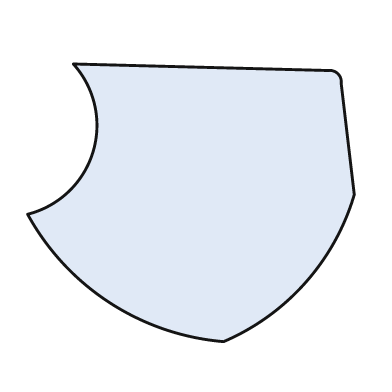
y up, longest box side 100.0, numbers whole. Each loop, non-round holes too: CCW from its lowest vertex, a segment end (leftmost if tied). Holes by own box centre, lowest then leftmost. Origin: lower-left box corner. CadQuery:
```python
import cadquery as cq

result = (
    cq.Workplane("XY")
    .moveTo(60.0, 0.0)
    .threePointArc((85.0, 18.0), (100.0, 45.0))
    .lineTo(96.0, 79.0)
    .threePointArc((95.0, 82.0), (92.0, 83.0))
    .lineTo(14.0, 85.0)
    .threePointArc((20.0, 58.0), (0.0, 39.0))
    .threePointArc((25.0, 12.0), (60.0, 0.0))
    .close()
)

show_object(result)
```